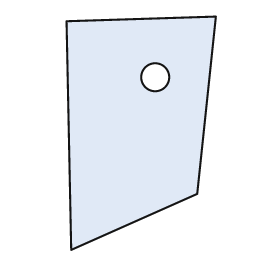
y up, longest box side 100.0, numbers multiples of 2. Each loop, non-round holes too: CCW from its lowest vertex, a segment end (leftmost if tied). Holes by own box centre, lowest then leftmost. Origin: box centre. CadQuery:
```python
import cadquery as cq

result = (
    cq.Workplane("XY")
    .moveTo(-30.0, -50.0)
    .lineTo(24.0, -26.0)
    .lineTo(32.0, 50.0)
    .lineTo(-32.0, 48.0)
    .close()
    .moveTo(6.0, 24.0)
    .circle(6.0)
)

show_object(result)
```